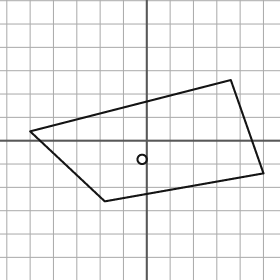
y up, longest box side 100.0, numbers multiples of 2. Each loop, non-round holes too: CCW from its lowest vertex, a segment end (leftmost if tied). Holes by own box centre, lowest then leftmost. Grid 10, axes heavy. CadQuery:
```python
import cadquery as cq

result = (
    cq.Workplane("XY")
    .moveTo(-18.0, -26.0)
    .lineTo(50.0, -14.0)
    .lineTo(36.0, 26.0)
    .lineTo(-50.0, 4.0)
    .close()
    .moveTo(-2.0, -8.0)
    .circle(2.0)
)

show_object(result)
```